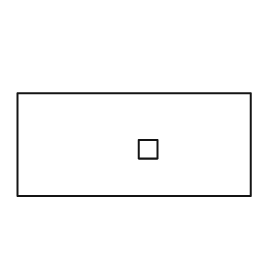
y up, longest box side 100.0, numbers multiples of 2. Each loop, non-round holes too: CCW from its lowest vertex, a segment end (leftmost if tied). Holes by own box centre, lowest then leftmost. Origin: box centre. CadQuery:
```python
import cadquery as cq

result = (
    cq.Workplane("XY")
    .moveTo(-50.0, -22.0)
    .lineTo(50.0, -22.0)
    .lineTo(50.0, 22.0)
    .lineTo(-50.0, 22.0)
    .close()
    .moveTo(2.0, -6.0)
    .lineTo(10.0, -6.0)
    .lineTo(10.0, 2.0)
    .lineTo(2.0, 2.0)
    .close()
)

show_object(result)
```